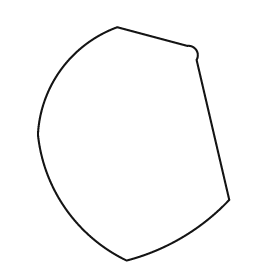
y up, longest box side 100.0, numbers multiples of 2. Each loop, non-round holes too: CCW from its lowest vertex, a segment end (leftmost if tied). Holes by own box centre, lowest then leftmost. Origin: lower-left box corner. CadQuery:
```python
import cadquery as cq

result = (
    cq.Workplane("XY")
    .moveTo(38.0, 0.0)
    .threePointArc((62.0, 10.0), (82.0, 26.0))
    .lineTo(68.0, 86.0)
    .threePointArc((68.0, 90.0), (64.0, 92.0))
    .lineTo(34.0, 100.0)
    .threePointArc((10.0, 82.0), (0.0, 54.0))
    .threePointArc((12.0, 22.0), (38.0, 0.0))
    .close()
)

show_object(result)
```